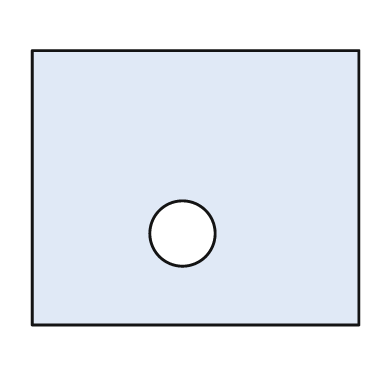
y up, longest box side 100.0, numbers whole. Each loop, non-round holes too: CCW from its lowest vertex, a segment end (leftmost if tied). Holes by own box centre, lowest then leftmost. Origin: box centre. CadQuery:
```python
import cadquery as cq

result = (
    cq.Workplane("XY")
    .moveTo(-50.0, -42.0)
    .lineTo(50.0, -42.0)
    .lineTo(50.0, 42.0)
    .lineTo(-50.0, 42.0)
    .close()
    .moveTo(-4.0, -14.0)
    .circle(10.0)
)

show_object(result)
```